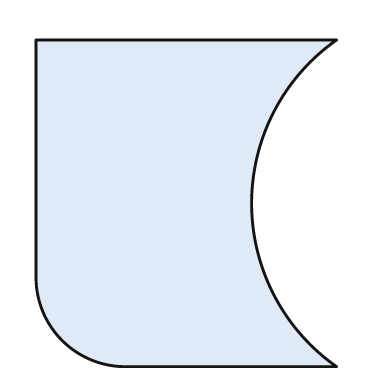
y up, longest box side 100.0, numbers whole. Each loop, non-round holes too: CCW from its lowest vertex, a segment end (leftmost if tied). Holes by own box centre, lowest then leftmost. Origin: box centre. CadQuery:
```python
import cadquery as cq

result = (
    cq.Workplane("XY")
    .moveTo(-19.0, -50.0)
    .lineTo(46.0, -50.0)
    .threePointArc((20.0, 0.0), (46.0, 50.0))
    .lineTo(-46.0, 50.0)
    .lineTo(-46.0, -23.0)
    .threePointArc((-38.0, -42.0), (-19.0, -50.0))
    .close()
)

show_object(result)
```